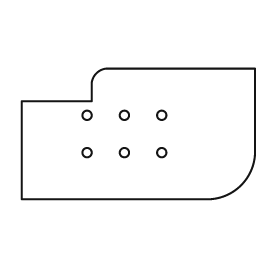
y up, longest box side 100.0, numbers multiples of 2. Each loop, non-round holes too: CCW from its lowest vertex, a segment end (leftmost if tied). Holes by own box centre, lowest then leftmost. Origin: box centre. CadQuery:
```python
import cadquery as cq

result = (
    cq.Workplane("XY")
    .moveTo(-50.0, -28.0)
    .lineTo(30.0, -28.0)
    .threePointArc((44.0, -22.0), (50.0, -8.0))
    .lineTo(50.0, 28.0)
    .lineTo(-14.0, 28.0)
    .threePointArc((-18.0, 26.0), (-20.0, 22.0))
    .lineTo(-20.0, 14.0)
    .lineTo(-50.0, 14.0)
    .close()
    .moveTo(-22.0, -8.0)
    .circle(2.0)
    .moveTo(-6.0, -8.0)
    .circle(2.0)
    .moveTo(10.0, -8.0)
    .circle(2.0)
    .moveTo(-22.0, 8.0)
    .circle(2.0)
    .moveTo(-6.0, 8.0)
    .circle(2.0)
    .moveTo(10.0, 8.0)
    .circle(2.0)
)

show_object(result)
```